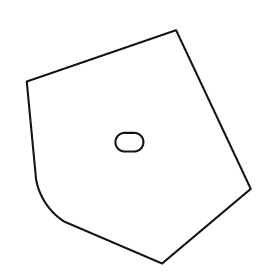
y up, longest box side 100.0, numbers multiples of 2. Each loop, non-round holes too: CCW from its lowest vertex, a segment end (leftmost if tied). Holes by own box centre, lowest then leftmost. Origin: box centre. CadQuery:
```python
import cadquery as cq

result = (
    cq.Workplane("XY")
    .moveTo(10.0, -50.0)
    .lineTo(48.0, -18.0)
    .lineTo(16.0, 50.0)
    .lineTo(-48.0, 28.0)
    .lineTo(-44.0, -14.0)
    .threePointArc((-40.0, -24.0), (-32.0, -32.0))
    .close()
    .moveTo(-6.0, -2.0)
    .lineTo(-2.0, -2.0)
    .threePointArc((2.0, 2.0), (-2.0, 6.0))
    .lineTo(-6.0, 6.0)
    .threePointArc((-10.0, 2.0), (-6.0, -2.0))
    .close()
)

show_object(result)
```